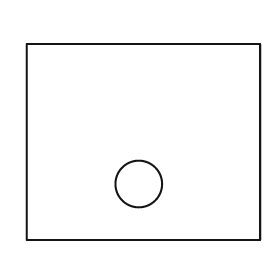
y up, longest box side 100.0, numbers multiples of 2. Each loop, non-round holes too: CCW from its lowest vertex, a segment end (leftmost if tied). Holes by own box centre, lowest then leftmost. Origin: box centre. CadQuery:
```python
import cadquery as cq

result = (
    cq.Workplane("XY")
    .moveTo(-50.0, -42.0)
    .lineTo(50.0, -42.0)
    .lineTo(50.0, 42.0)
    .lineTo(-50.0, 42.0)
    .close()
    .moveTo(-2.0, -18.0)
    .circle(10.0)
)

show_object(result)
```